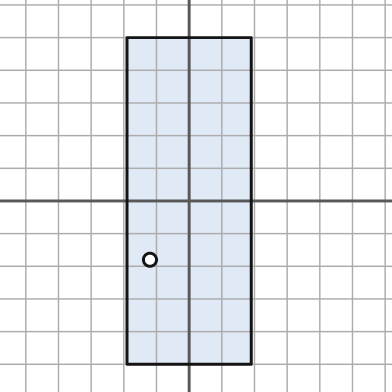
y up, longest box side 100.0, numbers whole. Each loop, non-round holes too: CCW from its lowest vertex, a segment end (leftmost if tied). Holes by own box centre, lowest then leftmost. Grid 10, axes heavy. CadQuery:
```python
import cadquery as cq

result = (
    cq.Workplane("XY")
    .moveTo(-19.0, -50.0)
    .lineTo(19.0, -50.0)
    .lineTo(19.0, 50.0)
    .lineTo(-19.0, 50.0)
    .close()
    .moveTo(-12.0, -18.0)
    .circle(2.0)
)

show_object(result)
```